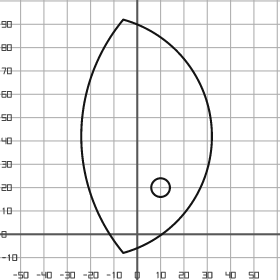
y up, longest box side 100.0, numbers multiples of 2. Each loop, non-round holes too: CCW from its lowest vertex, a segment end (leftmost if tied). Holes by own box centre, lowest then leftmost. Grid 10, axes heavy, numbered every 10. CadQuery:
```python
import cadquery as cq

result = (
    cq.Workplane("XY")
    .moveTo(-6.0, -8.0)
    .threePointArc((32.0, 42.0), (-6.0, 92.0))
    .threePointArc((-24.0, 42.0), (-6.0, -8.0))
    .close()
    .moveTo(10.0, 20.0)
    .circle(4.0)
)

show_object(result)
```